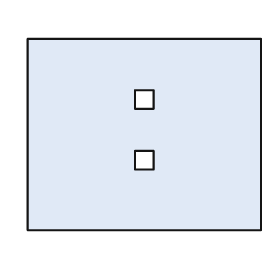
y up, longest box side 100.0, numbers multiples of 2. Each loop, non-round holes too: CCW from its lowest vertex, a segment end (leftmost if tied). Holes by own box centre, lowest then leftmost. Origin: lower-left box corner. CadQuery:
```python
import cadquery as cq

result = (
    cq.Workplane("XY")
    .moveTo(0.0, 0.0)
    .lineTo(100.0, 0.0)
    .lineTo(100.0, 82.0)
    .lineTo(0.0, 82.0)
    .close()
    .moveTo(46.0, 26.0)
    .lineTo(54.0, 26.0)
    .lineTo(54.0, 34.0)
    .lineTo(46.0, 34.0)
    .close()
    .moveTo(46.0, 52.0)
    .lineTo(54.0, 52.0)
    .lineTo(54.0, 60.0)
    .lineTo(46.0, 60.0)
    .close()
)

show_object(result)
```